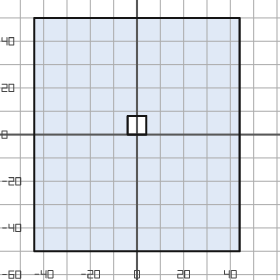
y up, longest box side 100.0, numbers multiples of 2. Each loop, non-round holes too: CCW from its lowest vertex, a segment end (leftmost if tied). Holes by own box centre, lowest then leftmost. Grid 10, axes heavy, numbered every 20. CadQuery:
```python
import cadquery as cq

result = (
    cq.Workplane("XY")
    .moveTo(-44.0, -50.0)
    .lineTo(44.0, -50.0)
    .lineTo(44.0, 50.0)
    .lineTo(-44.0, 50.0)
    .close()
    .moveTo(-4.0, 0.0)
    .lineTo(4.0, 0.0)
    .lineTo(4.0, 8.0)
    .lineTo(-4.0, 8.0)
    .close()
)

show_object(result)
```